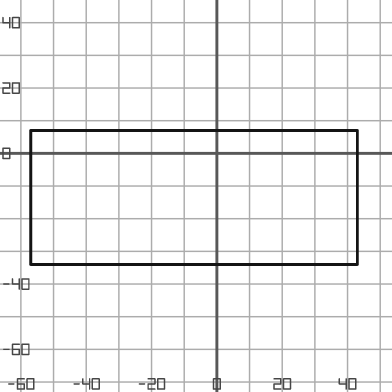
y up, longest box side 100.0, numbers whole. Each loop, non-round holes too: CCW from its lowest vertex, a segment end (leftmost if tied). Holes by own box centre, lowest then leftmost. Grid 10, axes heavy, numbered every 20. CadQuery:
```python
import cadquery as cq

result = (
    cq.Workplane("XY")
    .moveTo(-57.0, -34.0)
    .lineTo(43.0, -34.0)
    .lineTo(43.0, 7.0)
    .lineTo(-57.0, 7.0)
    .close()
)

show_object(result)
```